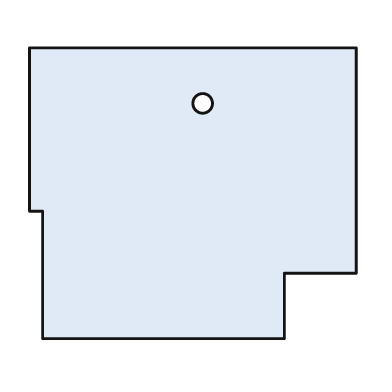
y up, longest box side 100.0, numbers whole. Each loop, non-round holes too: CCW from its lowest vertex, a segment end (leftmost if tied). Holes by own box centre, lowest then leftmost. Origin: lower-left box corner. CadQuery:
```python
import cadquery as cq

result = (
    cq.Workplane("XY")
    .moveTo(4.0, 0.0)
    .lineTo(78.0, 0.0)
    .lineTo(78.0, 20.0)
    .lineTo(100.0, 20.0)
    .lineTo(100.0, 89.0)
    .lineTo(0.0, 89.0)
    .lineTo(0.0, 39.0)
    .lineTo(4.0, 39.0)
    .close()
    .moveTo(53.0, 72.0)
    .circle(3.0)
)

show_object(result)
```